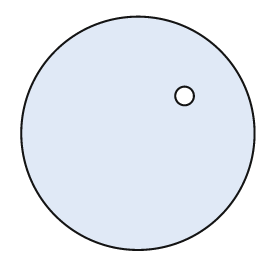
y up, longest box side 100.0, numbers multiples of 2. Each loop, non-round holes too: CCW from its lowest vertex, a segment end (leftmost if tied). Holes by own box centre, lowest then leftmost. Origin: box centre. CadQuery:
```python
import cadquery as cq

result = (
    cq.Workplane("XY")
    .moveTo(0.0, 0.0)
    .circle(50.0)
    .moveTo(20.0, 16.0)
    .circle(4.0)
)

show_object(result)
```